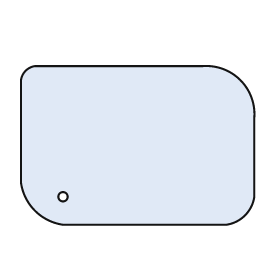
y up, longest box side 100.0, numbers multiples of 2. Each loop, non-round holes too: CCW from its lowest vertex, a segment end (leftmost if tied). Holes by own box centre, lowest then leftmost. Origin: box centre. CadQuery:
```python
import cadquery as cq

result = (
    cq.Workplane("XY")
    .moveTo(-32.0, -34.0)
    .lineTo(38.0, -34.0)
    .threePointArc((46.0, -30.0), (50.0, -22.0))
    .lineTo(50.0, 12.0)
    .threePointArc((44.0, 28.0), (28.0, 34.0))
    .lineTo(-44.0, 34.0)
    .threePointArc((-48.0, 32.0), (-50.0, 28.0))
    .lineTo(-50.0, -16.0)
    .threePointArc((-44.0, -28.0), (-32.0, -34.0))
    .close()
    .moveTo(-32.0, -22.0)
    .circle(2.0)
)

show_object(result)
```